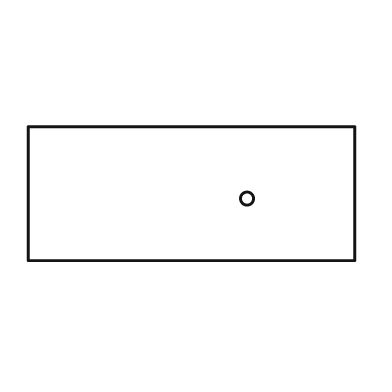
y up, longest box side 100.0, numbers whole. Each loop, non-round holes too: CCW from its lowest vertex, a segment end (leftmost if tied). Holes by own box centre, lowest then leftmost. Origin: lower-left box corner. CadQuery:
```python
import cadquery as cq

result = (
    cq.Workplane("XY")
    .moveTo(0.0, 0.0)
    .lineTo(100.0, 0.0)
    .lineTo(100.0, 41.0)
    .lineTo(0.0, 41.0)
    .close()
    .moveTo(67.0, 19.0)
    .circle(2.0)
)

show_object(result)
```